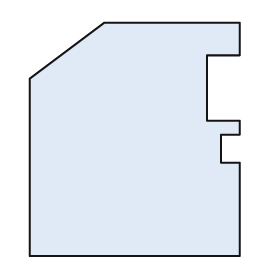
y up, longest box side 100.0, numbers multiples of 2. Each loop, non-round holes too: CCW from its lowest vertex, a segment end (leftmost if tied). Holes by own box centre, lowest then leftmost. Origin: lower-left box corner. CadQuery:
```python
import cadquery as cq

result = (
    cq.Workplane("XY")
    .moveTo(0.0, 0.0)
    .lineTo(90.0, 0.0)
    .lineTo(90.0, 40.0)
    .lineTo(82.0, 40.0)
    .lineTo(82.0, 52.0)
    .lineTo(90.0, 52.0)
    .lineTo(90.0, 58.0)
    .lineTo(76.0, 58.0)
    .lineTo(76.0, 86.0)
    .lineTo(90.0, 86.0)
    .lineTo(90.0, 100.0)
    .lineTo(32.0, 100.0)
    .lineTo(0.0, 76.0)
    .close()
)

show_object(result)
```